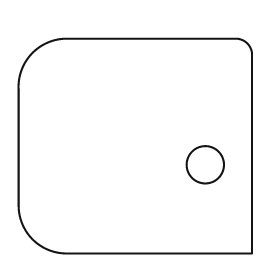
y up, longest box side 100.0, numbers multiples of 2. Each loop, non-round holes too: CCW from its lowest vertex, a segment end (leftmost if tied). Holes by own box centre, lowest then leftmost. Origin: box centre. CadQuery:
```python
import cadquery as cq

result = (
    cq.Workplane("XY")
    .moveTo(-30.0, -46.0)
    .lineTo(50.0, -46.0)
    .lineTo(50.0, 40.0)
    .threePointArc((48.0, 44.0), (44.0, 46.0))
    .lineTo(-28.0, 46.0)
    .threePointArc((-44.0, 40.0), (-50.0, 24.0))
    .lineTo(-50.0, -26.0)
    .threePointArc((-44.0, -40.0), (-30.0, -46.0))
    .close()
    .moveTo(30.0, -8.0)
    .circle(8.0)
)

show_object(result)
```